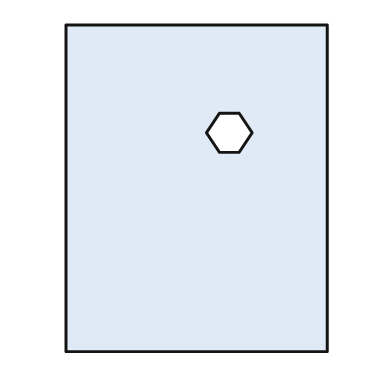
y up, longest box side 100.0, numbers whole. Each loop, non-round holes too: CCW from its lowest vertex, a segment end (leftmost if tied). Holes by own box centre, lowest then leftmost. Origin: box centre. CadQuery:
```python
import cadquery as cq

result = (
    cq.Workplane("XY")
    .moveTo(-40.0, -50.0)
    .lineTo(40.0, -50.0)
    .lineTo(40.0, 50.0)
    .lineTo(-40.0, 50.0)
    .close()
    .moveTo(7.0, 11.0)
    .lineTo(13.0, 11.0)
    .lineTo(17.0, 17.0)
    .lineTo(13.0, 23.0)
    .lineTo(7.0, 23.0)
    .lineTo(3.0, 17.0)
    .close()
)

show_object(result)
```